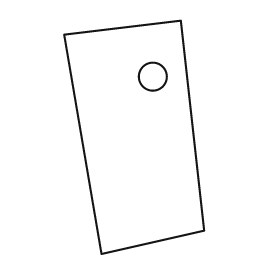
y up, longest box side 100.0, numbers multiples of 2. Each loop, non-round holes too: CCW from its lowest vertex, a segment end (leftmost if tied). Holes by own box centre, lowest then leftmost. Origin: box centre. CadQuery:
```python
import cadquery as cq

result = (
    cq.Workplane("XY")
    .moveTo(-14.0, -50.0)
    .lineTo(30.0, -40.0)
    .lineTo(20.0, 50.0)
    .lineTo(-30.0, 44.0)
    .close()
    .moveTo(8.0, 26.0)
    .circle(6.0)
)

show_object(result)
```